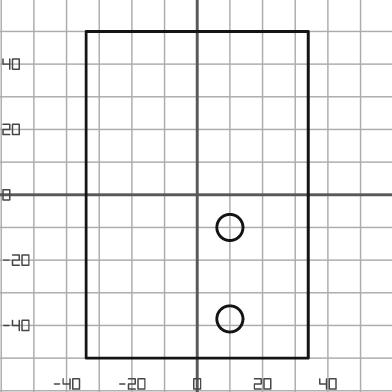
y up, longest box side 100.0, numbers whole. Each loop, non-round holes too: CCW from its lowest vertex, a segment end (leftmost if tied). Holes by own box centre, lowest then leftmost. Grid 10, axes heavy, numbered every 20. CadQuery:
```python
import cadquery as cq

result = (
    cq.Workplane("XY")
    .moveTo(-34.0, -50.0)
    .lineTo(34.0, -50.0)
    .lineTo(34.0, 50.0)
    .lineTo(-34.0, 50.0)
    .close()
    .moveTo(10.0, -38.0)
    .circle(4.0)
    .moveTo(10.0, -10.0)
    .circle(4.0)
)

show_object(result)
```